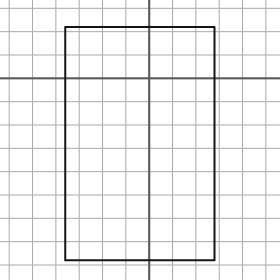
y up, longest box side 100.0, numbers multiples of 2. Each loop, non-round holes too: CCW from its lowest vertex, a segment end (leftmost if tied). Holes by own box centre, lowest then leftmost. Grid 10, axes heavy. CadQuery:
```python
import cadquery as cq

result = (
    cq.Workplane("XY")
    .moveTo(-36.0, -78.0)
    .lineTo(28.0, -78.0)
    .lineTo(28.0, 22.0)
    .lineTo(-36.0, 22.0)
    .close()
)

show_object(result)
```